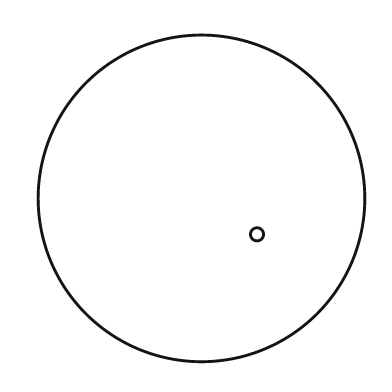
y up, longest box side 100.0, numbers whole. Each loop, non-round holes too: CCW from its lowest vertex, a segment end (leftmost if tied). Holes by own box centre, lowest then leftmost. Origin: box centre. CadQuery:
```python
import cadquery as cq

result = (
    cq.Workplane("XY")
    .moveTo(0.0, 0.0)
    .circle(50.0)
    .moveTo(17.0, -11.0)
    .circle(2.0)
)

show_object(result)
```